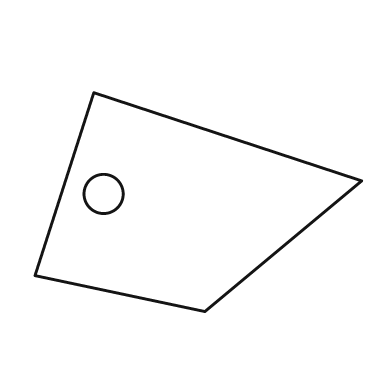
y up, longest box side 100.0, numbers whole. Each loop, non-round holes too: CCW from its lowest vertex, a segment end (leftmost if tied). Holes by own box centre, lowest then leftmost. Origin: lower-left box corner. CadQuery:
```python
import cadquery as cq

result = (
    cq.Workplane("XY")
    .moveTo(52.0, 0.0)
    .lineTo(100.0, 40.0)
    .lineTo(18.0, 67.0)
    .lineTo(0.0, 11.0)
    .close()
    .moveTo(21.0, 36.0)
    .circle(6.0)
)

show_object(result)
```